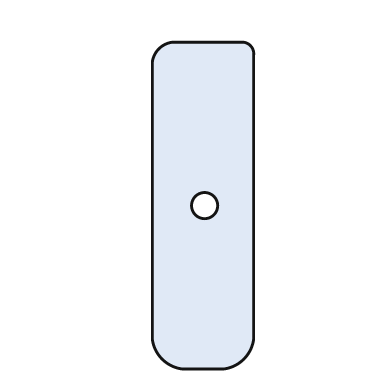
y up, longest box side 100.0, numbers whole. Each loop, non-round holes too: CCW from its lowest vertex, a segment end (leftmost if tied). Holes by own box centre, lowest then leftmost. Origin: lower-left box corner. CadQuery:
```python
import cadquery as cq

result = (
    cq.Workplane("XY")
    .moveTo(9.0, 0.0)
    .lineTo(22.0, 0.0)
    .threePointArc((28.0, 3.0), (31.0, 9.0))
    .lineTo(31.0, 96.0)
    .threePointArc((30.0, 99.0), (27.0, 100.0))
    .lineTo(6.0, 100.0)
    .threePointArc((2.0, 98.0), (0.0, 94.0))
    .lineTo(0.0, 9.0)
    .threePointArc((3.0, 3.0), (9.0, 0.0))
    .close()
    .moveTo(16.0, 50.0)
    .circle(4.0)
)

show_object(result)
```